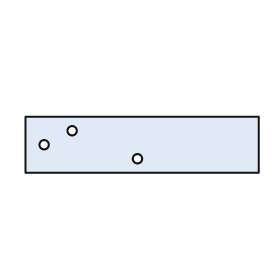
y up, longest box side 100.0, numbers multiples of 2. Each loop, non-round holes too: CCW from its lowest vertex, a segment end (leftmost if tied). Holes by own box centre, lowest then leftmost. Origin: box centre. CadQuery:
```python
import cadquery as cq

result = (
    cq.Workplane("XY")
    .moveTo(-50.0, -12.0)
    .lineTo(50.0, -12.0)
    .lineTo(50.0, 12.0)
    .lineTo(-50.0, 12.0)
    .close()
    .moveTo(-2.0, -6.0)
    .circle(2.0)
    .moveTo(-42.0, 0.0)
    .circle(2.0)
    .moveTo(-30.0, 6.0)
    .circle(2.0)
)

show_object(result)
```